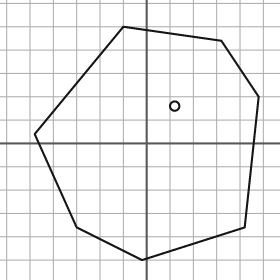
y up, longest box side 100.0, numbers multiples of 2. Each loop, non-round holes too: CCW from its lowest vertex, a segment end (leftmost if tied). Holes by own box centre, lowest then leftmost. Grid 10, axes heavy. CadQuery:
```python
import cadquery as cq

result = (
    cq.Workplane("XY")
    .moveTo(-2.0, -50.0)
    .lineTo(42.0, -36.0)
    .lineTo(48.0, 20.0)
    .lineTo(32.0, 44.0)
    .lineTo(-10.0, 50.0)
    .lineTo(-48.0, 4.0)
    .lineTo(-30.0, -36.0)
    .close()
    .moveTo(12.0, 16.0)
    .circle(2.0)
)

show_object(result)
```